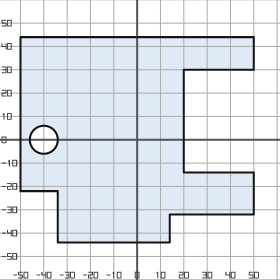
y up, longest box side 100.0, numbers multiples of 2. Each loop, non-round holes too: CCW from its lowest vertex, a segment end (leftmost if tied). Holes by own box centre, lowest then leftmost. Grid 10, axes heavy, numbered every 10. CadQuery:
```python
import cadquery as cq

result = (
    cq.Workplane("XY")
    .moveTo(-34.0, -44.0)
    .lineTo(14.0, -44.0)
    .lineTo(14.0, -32.0)
    .lineTo(50.0, -32.0)
    .lineTo(50.0, -14.0)
    .lineTo(20.0, -14.0)
    .lineTo(20.0, 30.0)
    .lineTo(50.0, 30.0)
    .lineTo(50.0, 44.0)
    .lineTo(-50.0, 44.0)
    .lineTo(-50.0, -22.0)
    .lineTo(-34.0, -22.0)
    .close()
    .moveTo(-40.0, 0.0)
    .circle(6.0)
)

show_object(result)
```